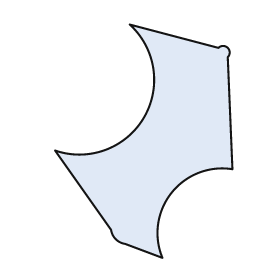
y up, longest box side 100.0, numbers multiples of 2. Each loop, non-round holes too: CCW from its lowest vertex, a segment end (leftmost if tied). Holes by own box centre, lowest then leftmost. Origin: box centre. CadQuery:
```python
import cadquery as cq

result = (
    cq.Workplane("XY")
    .moveTo(8.0, -50.0)
    .threePointArc((12.0, -22.0), (38.0, -12.0))
    .lineTo(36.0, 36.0)
    .threePointArc((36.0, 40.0), (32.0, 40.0))
    .lineTo(-6.0, 50.0)
    .threePointArc((0.0, 10.0), (-38.0, -4.0))
    .lineTo(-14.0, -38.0)
    .threePointArc((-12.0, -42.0), (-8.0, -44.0))
    .close()
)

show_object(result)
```